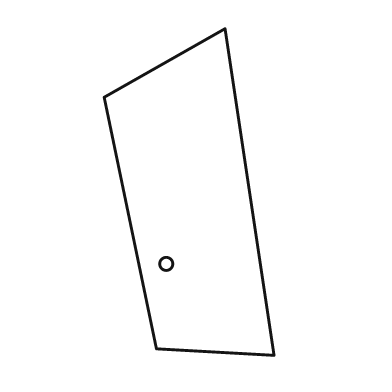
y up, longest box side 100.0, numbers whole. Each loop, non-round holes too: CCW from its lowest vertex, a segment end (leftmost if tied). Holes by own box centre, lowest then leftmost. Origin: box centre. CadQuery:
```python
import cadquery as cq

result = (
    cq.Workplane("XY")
    .moveTo(26.0, -50.0)
    .lineTo(11.0, 50.0)
    .lineTo(-26.0, 29.0)
    .lineTo(-10.0, -48.0)
    .close()
    .moveTo(-7.0, -22.0)
    .circle(2.0)
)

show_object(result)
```